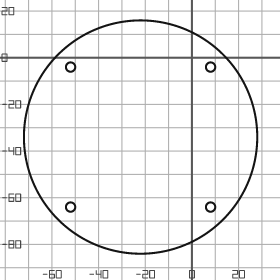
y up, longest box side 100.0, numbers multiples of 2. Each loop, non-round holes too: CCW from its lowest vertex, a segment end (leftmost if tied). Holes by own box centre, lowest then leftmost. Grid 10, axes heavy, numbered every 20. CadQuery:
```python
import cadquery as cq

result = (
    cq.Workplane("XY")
    .moveTo(-22.0, -34.0)
    .circle(50.0)
    .moveTo(-52.0, -64.0)
    .circle(2.0)
    .moveTo(8.0, -64.0)
    .circle(2.0)
    .moveTo(-52.0, -4.0)
    .circle(2.0)
    .moveTo(8.0, -4.0)
    .circle(2.0)
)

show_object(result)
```